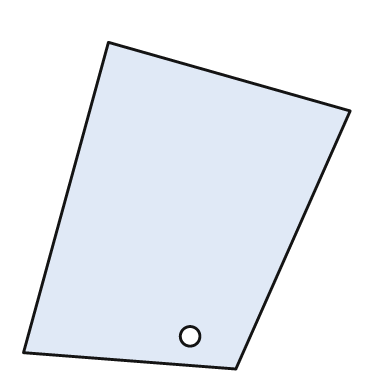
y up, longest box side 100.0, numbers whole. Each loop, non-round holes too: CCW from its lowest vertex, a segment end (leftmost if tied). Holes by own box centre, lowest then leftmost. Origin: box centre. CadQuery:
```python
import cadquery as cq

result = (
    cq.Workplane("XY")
    .moveTo(15.0, -50.0)
    .lineTo(50.0, 29.0)
    .lineTo(-24.0, 50.0)
    .lineTo(-50.0, -45.0)
    .close()
    .moveTo(1.0, -40.0)
    .circle(3.0)
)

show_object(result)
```